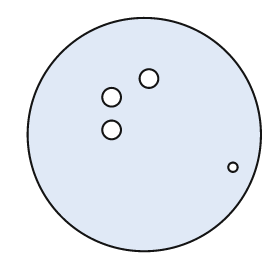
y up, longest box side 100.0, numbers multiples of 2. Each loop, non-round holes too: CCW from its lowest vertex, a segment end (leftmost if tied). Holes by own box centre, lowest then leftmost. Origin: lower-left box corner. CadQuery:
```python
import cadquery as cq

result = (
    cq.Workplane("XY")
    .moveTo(50.0, 50.0)
    .circle(50.0)
    .moveTo(88.0, 36.0)
    .circle(2.0)
    .moveTo(36.0, 52.0)
    .circle(4.0)
    .moveTo(36.0, 66.0)
    .circle(4.0)
    .moveTo(52.0, 74.0)
    .circle(4.0)
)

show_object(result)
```